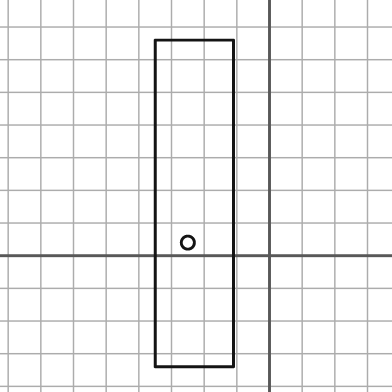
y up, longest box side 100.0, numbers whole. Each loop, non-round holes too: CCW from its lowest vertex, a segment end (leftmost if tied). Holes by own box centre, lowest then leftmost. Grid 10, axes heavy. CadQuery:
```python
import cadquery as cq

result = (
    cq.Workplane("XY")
    .moveTo(-35.0, -34.0)
    .lineTo(-11.0, -34.0)
    .lineTo(-11.0, 66.0)
    .lineTo(-35.0, 66.0)
    .close()
    .moveTo(-25.0, 4.0)
    .circle(2.0)
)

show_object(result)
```